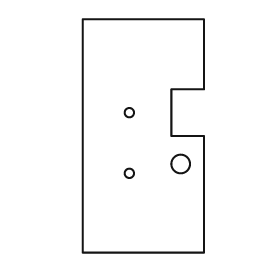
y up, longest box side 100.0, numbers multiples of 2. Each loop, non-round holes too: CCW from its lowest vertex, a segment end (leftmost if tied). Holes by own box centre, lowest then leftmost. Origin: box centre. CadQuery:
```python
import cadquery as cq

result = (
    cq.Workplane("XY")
    .moveTo(-26.0, -50.0)
    .lineTo(26.0, -50.0)
    .lineTo(26.0, 0.0)
    .lineTo(12.0, 0.0)
    .lineTo(12.0, 20.0)
    .lineTo(26.0, 20.0)
    .lineTo(26.0, 50.0)
    .lineTo(-26.0, 50.0)
    .close()
    .moveTo(-6.0, -16.0)
    .circle(2.0)
    .moveTo(16.0, -12.0)
    .circle(4.0)
    .moveTo(-6.0, 10.0)
    .circle(2.0)
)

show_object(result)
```